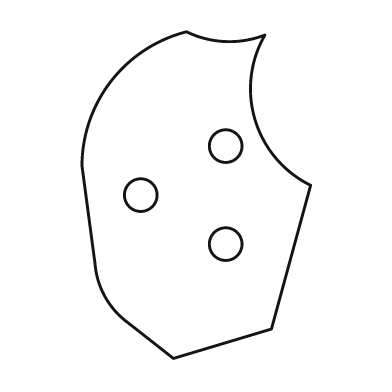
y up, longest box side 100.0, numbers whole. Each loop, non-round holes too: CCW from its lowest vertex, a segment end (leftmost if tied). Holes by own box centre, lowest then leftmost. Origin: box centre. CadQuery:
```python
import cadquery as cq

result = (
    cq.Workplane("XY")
    .moveTo(-7.0, -50.0)
    .lineTo(23.0, -41.0)
    .lineTo(35.0, 3.0)
    .threePointArc((18.0, 23.0), (21.0, 49.0))
    .threePointArc((9.0, 47.0), (-3.0, 50.0))
    .threePointArc((-26.0, 35.0), (-35.0, 9.0))
    .lineTo(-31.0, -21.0)
    .threePointArc((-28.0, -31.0), (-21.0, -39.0))
    .close()
    .moveTo(9.0, -15.0)
    .circle(5.0)
    .moveTo(-17.0, 0.0)
    .circle(5.0)
    .moveTo(9.0, 15.0)
    .circle(5.0)
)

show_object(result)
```